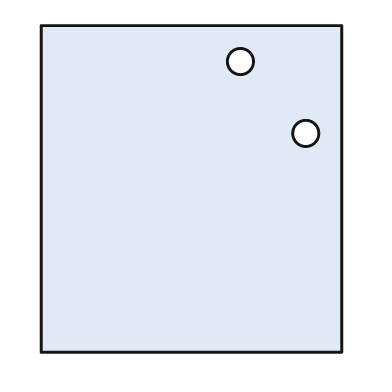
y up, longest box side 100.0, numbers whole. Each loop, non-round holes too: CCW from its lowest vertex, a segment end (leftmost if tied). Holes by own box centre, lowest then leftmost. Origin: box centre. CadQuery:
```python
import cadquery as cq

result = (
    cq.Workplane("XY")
    .moveTo(-46.0, -50.0)
    .lineTo(46.0, -50.0)
    .lineTo(46.0, 50.0)
    .lineTo(-46.0, 50.0)
    .close()
    .moveTo(35.0, 17.0)
    .circle(4.0)
    .moveTo(15.0, 39.0)
    .circle(4.0)
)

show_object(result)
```